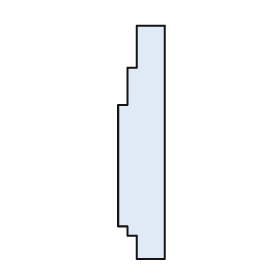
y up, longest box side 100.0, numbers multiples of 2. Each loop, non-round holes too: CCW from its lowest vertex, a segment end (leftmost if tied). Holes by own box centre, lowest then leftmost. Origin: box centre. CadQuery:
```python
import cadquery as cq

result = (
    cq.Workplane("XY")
    .moveTo(-2.0, -50.0)
    .lineTo(10.0, -50.0)
    .lineTo(10.0, 50.0)
    .lineTo(-2.0, 50.0)
    .lineTo(-2.0, 32.0)
    .lineTo(-6.0, 32.0)
    .lineTo(-6.0, 16.0)
    .lineTo(-10.0, 16.0)
    .lineTo(-10.0, -36.0)
    .lineTo(-6.0, -36.0)
    .lineTo(-6.0, -40.0)
    .lineTo(-2.0, -40.0)
    .close()
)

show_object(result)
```